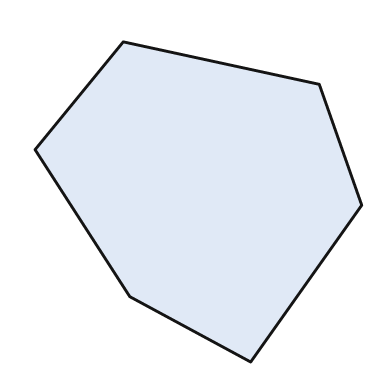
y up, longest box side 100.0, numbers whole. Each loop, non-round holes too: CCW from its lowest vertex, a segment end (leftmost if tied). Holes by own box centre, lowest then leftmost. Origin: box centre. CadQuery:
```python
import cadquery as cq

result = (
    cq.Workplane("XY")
    .moveTo(16.0, -49.0)
    .lineTo(50.0, -1.0)
    .lineTo(37.0, 36.0)
    .lineTo(-23.0, 49.0)
    .lineTo(-50.0, 16.0)
    .lineTo(-21.0, -29.0)
    .close()
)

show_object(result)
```